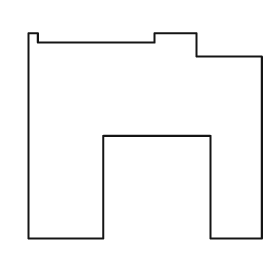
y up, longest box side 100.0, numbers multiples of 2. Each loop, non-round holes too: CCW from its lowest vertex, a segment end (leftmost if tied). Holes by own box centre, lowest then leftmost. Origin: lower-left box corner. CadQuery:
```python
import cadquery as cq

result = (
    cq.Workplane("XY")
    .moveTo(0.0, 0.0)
    .lineTo(32.0, 0.0)
    .lineTo(32.0, 44.0)
    .lineTo(78.0, 44.0)
    .lineTo(78.0, 0.0)
    .lineTo(100.0, 0.0)
    .lineTo(100.0, 78.0)
    .lineTo(72.0, 78.0)
    .lineTo(72.0, 88.0)
    .lineTo(54.0, 88.0)
    .lineTo(54.0, 84.0)
    .lineTo(4.0, 84.0)
    .lineTo(4.0, 88.0)
    .lineTo(0.0, 88.0)
    .close()
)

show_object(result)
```